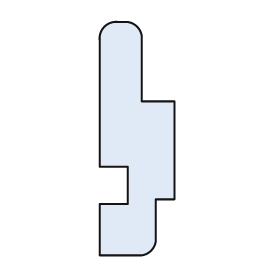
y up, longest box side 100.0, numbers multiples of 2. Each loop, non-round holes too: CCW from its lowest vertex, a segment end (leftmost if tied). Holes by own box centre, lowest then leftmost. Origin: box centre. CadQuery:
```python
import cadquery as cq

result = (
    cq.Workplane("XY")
    .moveTo(-16.0, -50.0)
    .lineTo(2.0, -50.0)
    .threePointArc((6.0, -48.0), (8.0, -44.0))
    .lineTo(8.0, -26.0)
    .lineTo(16.0, -26.0)
    .lineTo(16.0, 16.0)
    .lineTo(2.0, 16.0)
    .lineTo(2.0, 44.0)
    .threePointArc((0.0, 48.0), (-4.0, 50.0))
    .lineTo(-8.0, 50.0)
    .threePointArc((-14.0, 48.0), (-16.0, 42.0))
    .lineTo(-16.0, -12.0)
    .lineTo(-4.0, -12.0)
    .lineTo(-4.0, -28.0)
    .lineTo(-16.0, -28.0)
    .close()
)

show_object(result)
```